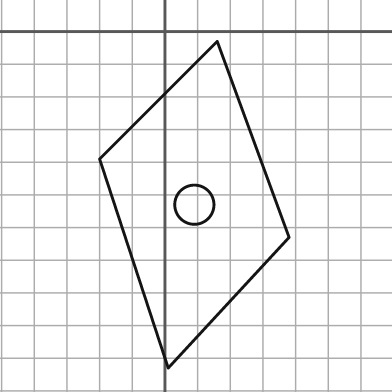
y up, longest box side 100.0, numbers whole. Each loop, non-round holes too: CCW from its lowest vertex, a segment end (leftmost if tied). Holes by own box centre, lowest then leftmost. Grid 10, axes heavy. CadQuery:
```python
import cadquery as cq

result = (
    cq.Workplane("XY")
    .moveTo(1.0, -103.0)
    .lineTo(38.0, -63.0)
    .lineTo(16.0, -3.0)
    .lineTo(-20.0, -39.0)
    .close()
    .moveTo(9.0, -53.0)
    .circle(6.0)
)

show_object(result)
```